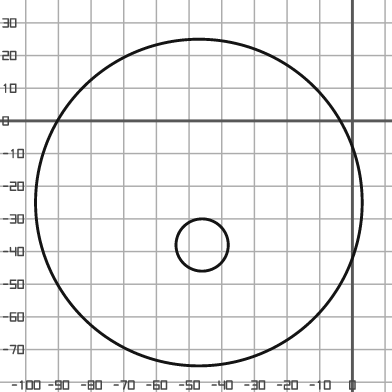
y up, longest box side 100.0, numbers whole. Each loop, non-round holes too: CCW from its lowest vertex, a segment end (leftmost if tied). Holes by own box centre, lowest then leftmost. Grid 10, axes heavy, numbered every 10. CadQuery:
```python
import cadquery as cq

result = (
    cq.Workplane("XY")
    .moveTo(-47.0, -25.0)
    .circle(50.0)
    .moveTo(-46.0, -38.0)
    .circle(8.0)
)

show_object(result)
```